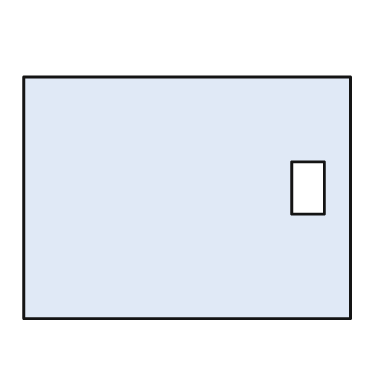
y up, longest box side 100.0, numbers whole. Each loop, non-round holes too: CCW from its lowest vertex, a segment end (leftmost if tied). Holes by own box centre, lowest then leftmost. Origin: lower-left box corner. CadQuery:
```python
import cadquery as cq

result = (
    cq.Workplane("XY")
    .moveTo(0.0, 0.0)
    .lineTo(100.0, 0.0)
    .lineTo(100.0, 74.0)
    .lineTo(0.0, 74.0)
    .close()
    .moveTo(82.0, 32.0)
    .lineTo(92.0, 32.0)
    .lineTo(92.0, 48.0)
    .lineTo(82.0, 48.0)
    .close()
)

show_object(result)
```